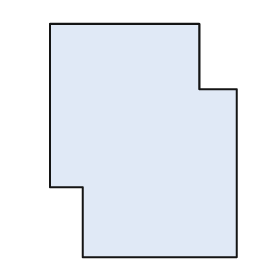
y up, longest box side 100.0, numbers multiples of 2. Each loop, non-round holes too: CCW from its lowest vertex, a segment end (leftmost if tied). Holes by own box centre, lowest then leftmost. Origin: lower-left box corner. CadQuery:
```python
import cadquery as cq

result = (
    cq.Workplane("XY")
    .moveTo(14.0, 0.0)
    .lineTo(80.0, 0.0)
    .lineTo(80.0, 72.0)
    .lineTo(64.0, 72.0)
    .lineTo(64.0, 100.0)
    .lineTo(0.0, 100.0)
    .lineTo(0.0, 30.0)
    .lineTo(14.0, 30.0)
    .close()
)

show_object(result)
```